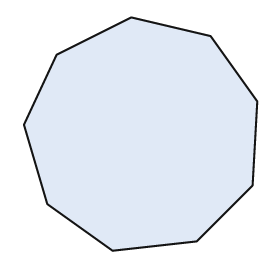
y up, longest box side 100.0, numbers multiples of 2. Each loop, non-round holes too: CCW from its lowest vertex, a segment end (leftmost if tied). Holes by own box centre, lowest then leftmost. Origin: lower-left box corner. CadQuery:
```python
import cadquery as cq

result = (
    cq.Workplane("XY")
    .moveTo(38.0, 0.0)
    .lineTo(74.0, 4.0)
    .lineTo(98.0, 28.0)
    .lineTo(100.0, 64.0)
    .lineTo(80.0, 92.0)
    .lineTo(46.0, 100.0)
    .lineTo(14.0, 84.0)
    .lineTo(0.0, 54.0)
    .lineTo(10.0, 20.0)
    .close()
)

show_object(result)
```